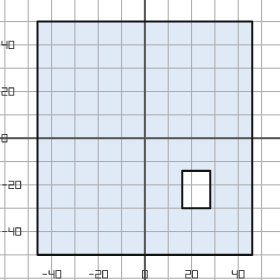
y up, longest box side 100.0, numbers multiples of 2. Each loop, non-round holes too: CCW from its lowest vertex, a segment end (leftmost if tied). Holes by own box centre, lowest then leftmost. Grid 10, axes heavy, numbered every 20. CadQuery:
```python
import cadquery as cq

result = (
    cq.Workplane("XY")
    .moveTo(-46.0, -50.0)
    .lineTo(46.0, -50.0)
    .lineTo(46.0, 50.0)
    .lineTo(-46.0, 50.0)
    .close()
    .moveTo(16.0, -30.0)
    .lineTo(28.0, -30.0)
    .lineTo(28.0, -14.0)
    .lineTo(16.0, -14.0)
    .close()
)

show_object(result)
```